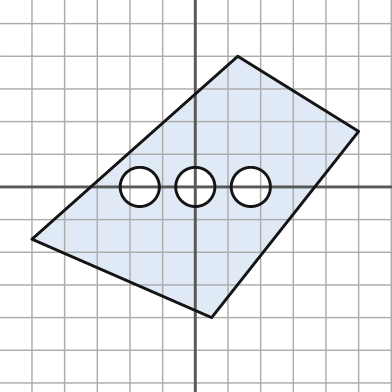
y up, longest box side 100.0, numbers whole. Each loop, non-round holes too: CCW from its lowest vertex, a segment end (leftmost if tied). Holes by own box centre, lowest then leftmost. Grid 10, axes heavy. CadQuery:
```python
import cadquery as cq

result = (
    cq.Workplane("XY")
    .moveTo(5.0, -40.0)
    .lineTo(50.0, 17.0)
    .lineTo(13.0, 40.0)
    .lineTo(-50.0, -16.0)
    .close()
    .moveTo(-17.0, 0.0)
    .circle(6.0)
    .moveTo(0.0, 0.0)
    .circle(6.0)
    .moveTo(17.0, 0.0)
    .circle(6.0)
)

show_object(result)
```